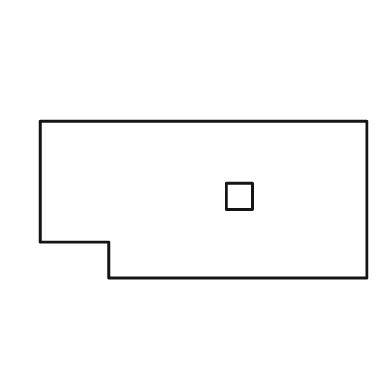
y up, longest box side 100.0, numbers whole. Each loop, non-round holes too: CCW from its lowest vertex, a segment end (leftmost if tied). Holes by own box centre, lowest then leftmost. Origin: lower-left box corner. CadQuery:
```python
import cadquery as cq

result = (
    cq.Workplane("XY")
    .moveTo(21.0, 0.0)
    .lineTo(100.0, 0.0)
    .lineTo(100.0, 48.0)
    .lineTo(0.0, 48.0)
    .lineTo(0.0, 11.0)
    .lineTo(21.0, 11.0)
    .close()
    .moveTo(57.0, 21.0)
    .lineTo(65.0, 21.0)
    .lineTo(65.0, 29.0)
    .lineTo(57.0, 29.0)
    .close()
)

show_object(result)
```